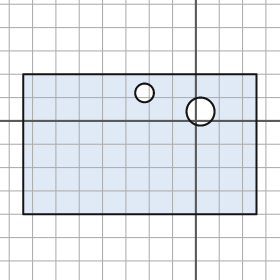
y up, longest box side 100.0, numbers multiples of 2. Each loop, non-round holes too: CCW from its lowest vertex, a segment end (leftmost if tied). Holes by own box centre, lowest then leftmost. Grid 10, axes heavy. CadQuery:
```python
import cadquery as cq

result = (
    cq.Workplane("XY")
    .moveTo(-74.0, -40.0)
    .lineTo(26.0, -40.0)
    .lineTo(26.0, 20.0)
    .lineTo(-74.0, 20.0)
    .close()
    .moveTo(2.0, 4.0)
    .circle(6.0)
    .moveTo(-22.0, 12.0)
    .circle(4.0)
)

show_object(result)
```